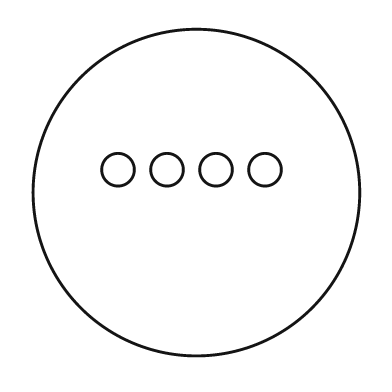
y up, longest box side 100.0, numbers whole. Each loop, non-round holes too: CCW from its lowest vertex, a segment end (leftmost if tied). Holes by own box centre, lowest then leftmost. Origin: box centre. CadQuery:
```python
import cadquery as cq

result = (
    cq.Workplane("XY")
    .moveTo(0.0, 0.0)
    .circle(50.0)
    .moveTo(-24.0, 7.0)
    .circle(5.0)
    .moveTo(-9.0, 7.0)
    .circle(5.0)
    .moveTo(6.0, 7.0)
    .circle(5.0)
    .moveTo(21.0, 7.0)
    .circle(5.0)
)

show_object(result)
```